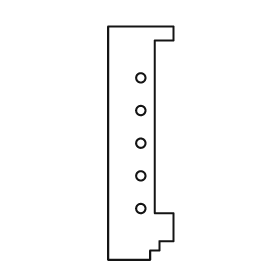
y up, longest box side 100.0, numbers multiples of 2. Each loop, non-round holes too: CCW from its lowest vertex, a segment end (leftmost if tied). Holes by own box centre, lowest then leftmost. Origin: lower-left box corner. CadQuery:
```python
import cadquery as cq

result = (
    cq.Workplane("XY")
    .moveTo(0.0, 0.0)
    .lineTo(18.0, 0.0)
    .lineTo(18.0, 4.0)
    .lineTo(22.0, 4.0)
    .lineTo(22.0, 8.0)
    .lineTo(28.0, 8.0)
    .lineTo(28.0, 20.0)
    .lineTo(20.0, 20.0)
    .lineTo(20.0, 94.0)
    .lineTo(28.0, 94.0)
    .lineTo(28.0, 100.0)
    .lineTo(0.0, 100.0)
    .close()
    .moveTo(14.0, 22.0)
    .circle(2.0)
    .moveTo(14.0, 36.0)
    .circle(2.0)
    .moveTo(14.0, 50.0)
    .circle(2.0)
    .moveTo(14.0, 64.0)
    .circle(2.0)
    .moveTo(14.0, 78.0)
    .circle(2.0)
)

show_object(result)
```